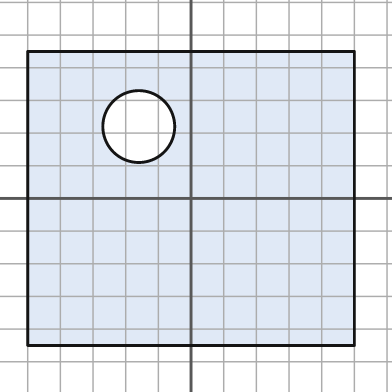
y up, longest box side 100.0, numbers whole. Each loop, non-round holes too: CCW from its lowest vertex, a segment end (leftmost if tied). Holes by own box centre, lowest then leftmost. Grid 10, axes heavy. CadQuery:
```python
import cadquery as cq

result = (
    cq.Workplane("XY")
    .moveTo(-50.0, -45.0)
    .lineTo(50.0, -45.0)
    .lineTo(50.0, 45.0)
    .lineTo(-50.0, 45.0)
    .close()
    .moveTo(-16.0, 22.0)
    .circle(11.0)
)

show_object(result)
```